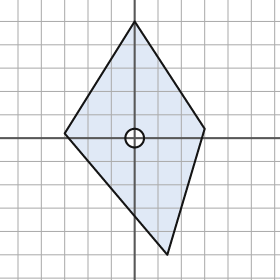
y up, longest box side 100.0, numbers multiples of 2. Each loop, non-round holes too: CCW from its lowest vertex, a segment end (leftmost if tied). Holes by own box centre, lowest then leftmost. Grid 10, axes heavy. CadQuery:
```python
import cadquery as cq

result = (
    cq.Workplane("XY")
    .moveTo(14.0, -50.0)
    .lineTo(30.0, 4.0)
    .lineTo(0.0, 50.0)
    .lineTo(-30.0, 2.0)
    .close()
    .moveTo(0.0, 0.0)
    .circle(4.0)
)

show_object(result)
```